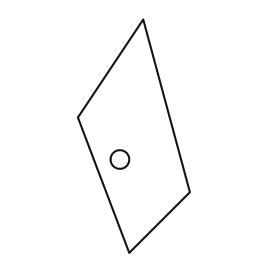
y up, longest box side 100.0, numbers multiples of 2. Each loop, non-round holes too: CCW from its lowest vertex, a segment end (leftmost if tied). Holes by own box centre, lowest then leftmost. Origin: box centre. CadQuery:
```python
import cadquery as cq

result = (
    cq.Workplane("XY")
    .moveTo(-2.0, -50.0)
    .lineTo(24.0, -24.0)
    .lineTo(4.0, 50.0)
    .lineTo(-24.0, 8.0)
    .close()
    .moveTo(-6.0, -10.0)
    .circle(4.0)
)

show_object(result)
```